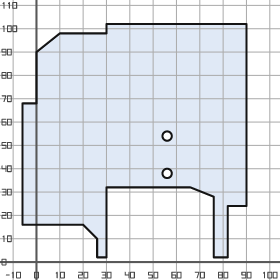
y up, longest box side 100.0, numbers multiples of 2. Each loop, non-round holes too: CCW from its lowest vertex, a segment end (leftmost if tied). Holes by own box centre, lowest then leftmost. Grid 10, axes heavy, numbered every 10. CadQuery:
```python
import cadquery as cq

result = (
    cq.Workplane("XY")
    .moveTo(26.0, 2.0)
    .lineTo(30.0, 2.0)
    .lineTo(30.0, 32.0)
    .lineTo(66.0, 32.0)
    .lineTo(76.0, 28.0)
    .lineTo(76.0, 2.0)
    .lineTo(82.0, 2.0)
    .lineTo(82.0, 24.0)
    .lineTo(90.0, 24.0)
    .lineTo(90.0, 102.0)
    .lineTo(30.0, 102.0)
    .lineTo(30.0, 98.0)
    .lineTo(10.0, 98.0)
    .lineTo(0.0, 90.0)
    .lineTo(0.0, 68.0)
    .lineTo(-6.0, 68.0)
    .lineTo(-6.0, 16.0)
    .lineTo(20.0, 16.0)
    .lineTo(26.0, 10.0)
    .close()
    .moveTo(56.0, 38.0)
    .circle(2.0)
    .moveTo(56.0, 54.0)
    .circle(2.0)
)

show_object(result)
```